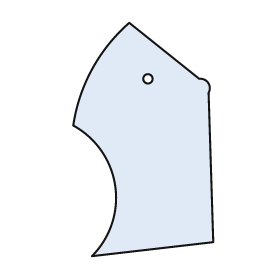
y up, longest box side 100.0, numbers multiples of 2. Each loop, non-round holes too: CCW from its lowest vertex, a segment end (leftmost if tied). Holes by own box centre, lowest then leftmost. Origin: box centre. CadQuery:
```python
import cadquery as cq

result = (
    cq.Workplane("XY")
    .moveTo(-22.0, -50.0)
    .lineTo(30.0, -44.0)
    .lineTo(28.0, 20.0)
    .threePointArc((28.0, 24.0), (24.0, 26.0))
    .lineTo(-6.0, 50.0)
    .threePointArc((-22.0, 30.0), (-30.0, 6.0))
    .threePointArc((-12.0, -20.0), (-22.0, -50.0))
    .close()
    .moveTo(2.0, 26.0)
    .circle(2.0)
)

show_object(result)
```